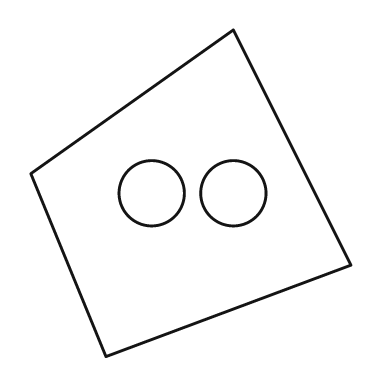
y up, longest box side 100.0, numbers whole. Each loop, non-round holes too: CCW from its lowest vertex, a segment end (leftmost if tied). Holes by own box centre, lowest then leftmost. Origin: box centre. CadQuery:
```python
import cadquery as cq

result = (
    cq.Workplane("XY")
    .moveTo(-26.0, -50.0)
    .lineTo(49.0, -22.0)
    .lineTo(13.0, 50.0)
    .lineTo(-49.0, 6.0)
    .close()
    .moveTo(-12.0, 0.0)
    .circle(10.0)
    .moveTo(13.0, 0.0)
    .circle(10.0)
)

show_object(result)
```